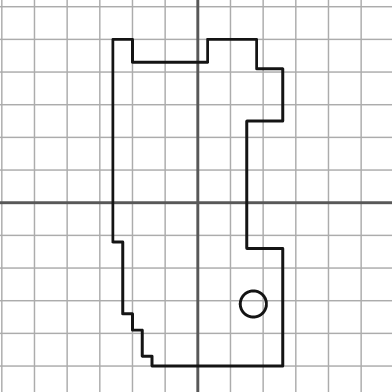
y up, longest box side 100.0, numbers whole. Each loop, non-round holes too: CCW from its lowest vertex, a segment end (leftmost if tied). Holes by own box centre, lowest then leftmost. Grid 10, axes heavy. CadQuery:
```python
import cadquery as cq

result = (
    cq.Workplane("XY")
    .moveTo(-14.0, -50.0)
    .lineTo(26.0, -50.0)
    .lineTo(26.0, -14.0)
    .lineTo(15.0, -14.0)
    .lineTo(15.0, 25.0)
    .lineTo(26.0, 25.0)
    .lineTo(26.0, 41.0)
    .lineTo(18.0, 41.0)
    .lineTo(18.0, 50.0)
    .lineTo(3.0, 50.0)
    .lineTo(3.0, 43.0)
    .lineTo(-20.0, 43.0)
    .lineTo(-20.0, 50.0)
    .lineTo(-26.0, 50.0)
    .lineTo(-26.0, -12.0)
    .lineTo(-23.0, -12.0)
    .lineTo(-23.0, -34.0)
    .lineTo(-20.0, -34.0)
    .lineTo(-20.0, -39.0)
    .lineTo(-17.0, -39.0)
    .lineTo(-17.0, -47.0)
    .lineTo(-14.0, -47.0)
    .close()
    .moveTo(17.0, -31.0)
    .circle(4.0)
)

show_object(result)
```